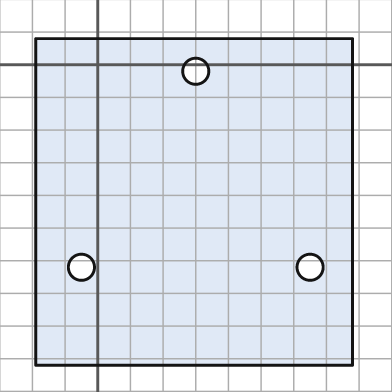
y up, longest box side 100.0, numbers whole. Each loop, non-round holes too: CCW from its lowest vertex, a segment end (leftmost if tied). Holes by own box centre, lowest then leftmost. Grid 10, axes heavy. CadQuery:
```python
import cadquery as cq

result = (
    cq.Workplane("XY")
    .moveTo(-19.0, -92.0)
    .lineTo(78.0, -92.0)
    .lineTo(78.0, 8.0)
    .lineTo(-19.0, 8.0)
    .close()
    .moveTo(-5.0, -62.0)
    .circle(4.0)
    .moveTo(65.0, -62.0)
    .circle(4.0)
    .moveTo(30.0, -2.0)
    .circle(4.0)
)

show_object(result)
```